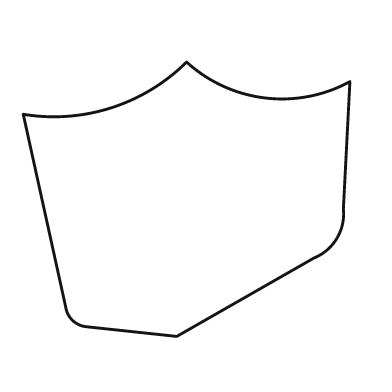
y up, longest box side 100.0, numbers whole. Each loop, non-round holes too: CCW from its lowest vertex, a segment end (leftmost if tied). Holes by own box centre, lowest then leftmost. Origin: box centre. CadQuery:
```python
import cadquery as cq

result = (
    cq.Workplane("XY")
    .moveTo(-3.0, -42.0)
    .lineTo(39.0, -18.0)
    .threePointArc((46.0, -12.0), (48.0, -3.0))
    .lineTo(50.0, 36.0)
    .threePointArc((24.0, 31.0), (0.0, 42.0))
    .threePointArc((-23.0, 28.0), (-50.0, 26.0))
    .lineTo(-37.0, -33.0)
    .threePointArc((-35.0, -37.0), (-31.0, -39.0))
    .close()
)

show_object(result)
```